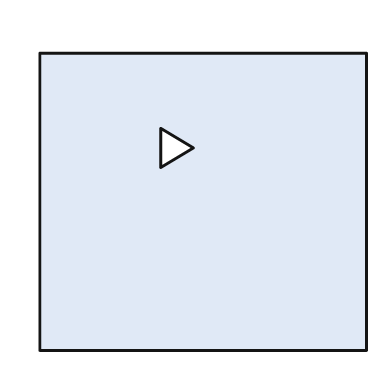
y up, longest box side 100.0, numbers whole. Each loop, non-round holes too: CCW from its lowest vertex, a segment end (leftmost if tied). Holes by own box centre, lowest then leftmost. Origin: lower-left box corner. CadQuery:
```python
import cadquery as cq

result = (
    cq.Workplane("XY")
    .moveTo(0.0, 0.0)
    .lineTo(100.0, 0.0)
    .lineTo(100.0, 91.0)
    .lineTo(0.0, 91.0)
    .close()
    .moveTo(37.0, 56.0)
    .lineTo(47.0, 62.0)
    .lineTo(37.0, 68.0)
    .close()
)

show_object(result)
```